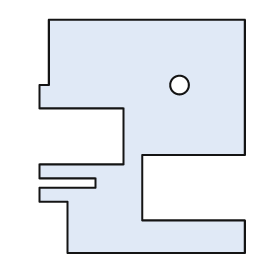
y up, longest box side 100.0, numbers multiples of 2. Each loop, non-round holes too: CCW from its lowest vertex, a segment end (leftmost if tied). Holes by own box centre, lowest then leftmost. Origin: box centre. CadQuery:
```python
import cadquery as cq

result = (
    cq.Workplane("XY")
    .moveTo(-32.0, -50.0)
    .lineTo(44.0, -50.0)
    .lineTo(44.0, -36.0)
    .lineTo(0.0, -36.0)
    .lineTo(0.0, -8.0)
    .lineTo(44.0, -8.0)
    .lineTo(44.0, 50.0)
    .lineTo(-40.0, 50.0)
    .lineTo(-40.0, 22.0)
    .lineTo(-44.0, 22.0)
    .lineTo(-44.0, 12.0)
    .lineTo(-8.0, 12.0)
    .lineTo(-8.0, -12.0)
    .lineTo(-44.0, -12.0)
    .lineTo(-44.0, -18.0)
    .lineTo(-20.0, -18.0)
    .lineTo(-20.0, -22.0)
    .lineTo(-44.0, -22.0)
    .lineTo(-44.0, -28.0)
    .lineTo(-32.0, -28.0)
    .close()
    .moveTo(16.0, 22.0)
    .circle(4.0)
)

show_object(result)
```